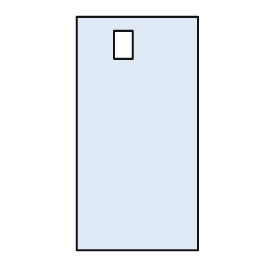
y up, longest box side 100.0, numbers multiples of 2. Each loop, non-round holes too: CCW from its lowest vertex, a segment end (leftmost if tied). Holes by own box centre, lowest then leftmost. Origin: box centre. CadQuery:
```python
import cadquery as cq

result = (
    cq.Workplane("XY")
    .moveTo(-26.0, -50.0)
    .lineTo(26.0, -50.0)
    .lineTo(26.0, 50.0)
    .lineTo(-26.0, 50.0)
    .close()
    .moveTo(-10.0, 32.0)
    .lineTo(-2.0, 32.0)
    .lineTo(-2.0, 44.0)
    .lineTo(-10.0, 44.0)
    .close()
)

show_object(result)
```